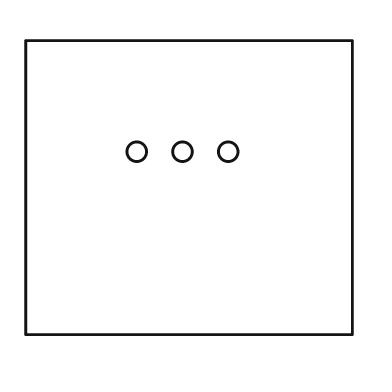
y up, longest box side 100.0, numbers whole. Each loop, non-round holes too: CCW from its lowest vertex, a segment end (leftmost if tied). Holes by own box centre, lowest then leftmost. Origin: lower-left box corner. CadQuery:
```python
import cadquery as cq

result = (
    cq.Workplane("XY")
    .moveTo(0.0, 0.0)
    .lineTo(100.0, 0.0)
    .lineTo(100.0, 90.0)
    .lineTo(0.0, 90.0)
    .close()
    .moveTo(34.0, 56.0)
    .circle(3.0)
    .moveTo(48.0, 56.0)
    .circle(3.0)
    .moveTo(62.0, 56.0)
    .circle(3.0)
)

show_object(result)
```